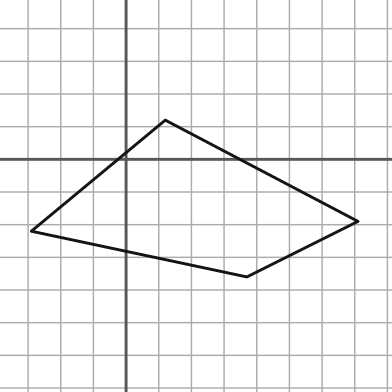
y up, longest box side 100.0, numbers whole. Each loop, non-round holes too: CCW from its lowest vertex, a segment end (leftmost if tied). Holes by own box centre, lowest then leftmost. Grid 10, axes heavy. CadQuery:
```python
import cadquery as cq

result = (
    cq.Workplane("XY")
    .moveTo(37.0, -36.0)
    .lineTo(71.0, -19.0)
    .lineTo(12.0, 12.0)
    .lineTo(-29.0, -22.0)
    .close()
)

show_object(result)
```